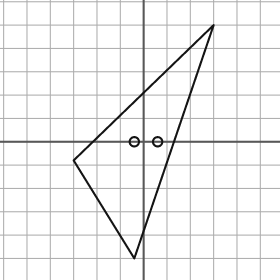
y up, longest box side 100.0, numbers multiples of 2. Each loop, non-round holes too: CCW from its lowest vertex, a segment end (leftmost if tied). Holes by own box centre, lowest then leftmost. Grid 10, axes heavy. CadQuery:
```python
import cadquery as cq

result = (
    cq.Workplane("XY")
    .moveTo(-4.0, -50.0)
    .lineTo(30.0, 50.0)
    .lineTo(-30.0, -8.0)
    .close()
    .moveTo(-4.0, 0.0)
    .circle(2.0)
    .moveTo(6.0, 0.0)
    .circle(2.0)
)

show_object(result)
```